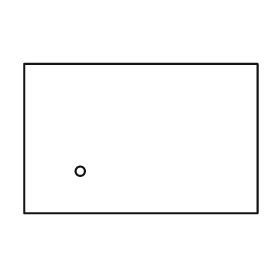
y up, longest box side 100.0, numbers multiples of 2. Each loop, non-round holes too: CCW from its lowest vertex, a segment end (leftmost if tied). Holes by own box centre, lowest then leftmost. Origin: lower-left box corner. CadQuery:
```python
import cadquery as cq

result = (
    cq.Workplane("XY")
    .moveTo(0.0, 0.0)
    .lineTo(100.0, 0.0)
    .lineTo(100.0, 64.0)
    .lineTo(0.0, 64.0)
    .close()
    .moveTo(24.0, 18.0)
    .circle(2.0)
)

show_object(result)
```